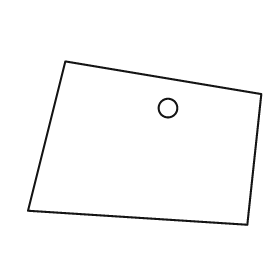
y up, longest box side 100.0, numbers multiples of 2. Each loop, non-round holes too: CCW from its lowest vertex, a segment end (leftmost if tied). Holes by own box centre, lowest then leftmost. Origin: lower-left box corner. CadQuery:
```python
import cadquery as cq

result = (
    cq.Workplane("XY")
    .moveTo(94.0, 0.0)
    .lineTo(100.0, 56.0)
    .lineTo(16.0, 70.0)
    .lineTo(0.0, 6.0)
    .close()
    .moveTo(60.0, 50.0)
    .circle(4.0)
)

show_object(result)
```